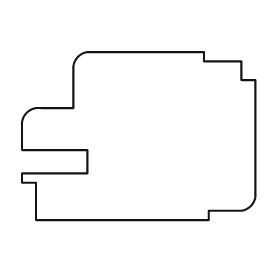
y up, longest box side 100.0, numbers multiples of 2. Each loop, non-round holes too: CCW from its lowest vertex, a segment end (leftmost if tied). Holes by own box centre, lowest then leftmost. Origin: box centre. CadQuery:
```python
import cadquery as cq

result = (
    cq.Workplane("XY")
    .moveTo(-44.0, -36.0)
    .lineTo(30.0, -36.0)
    .lineTo(30.0, -32.0)
    .lineTo(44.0, -32.0)
    .threePointArc((48.0, -30.0), (50.0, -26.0))
    .lineTo(50.0, 24.0)
    .lineTo(44.0, 24.0)
    .lineTo(44.0, 32.0)
    .lineTo(28.0, 32.0)
    .lineTo(28.0, 36.0)
    .lineTo(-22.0, 36.0)
    .threePointArc((-26.0, 34.0), (-28.0, 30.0))
    .lineTo(-28.0, 12.0)
    .lineTo(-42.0, 12.0)
    .threePointArc((-48.0, 10.0), (-50.0, 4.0))
    .lineTo(-50.0, -6.0)
    .lineTo(-22.0, -6.0)
    .lineTo(-22.0, -16.0)
    .lineTo(-50.0, -16.0)
    .lineTo(-50.0, -20.0)
    .lineTo(-44.0, -20.0)
    .close()
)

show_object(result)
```